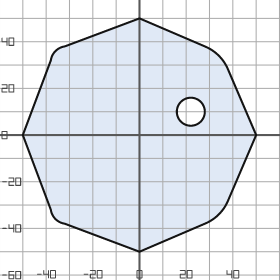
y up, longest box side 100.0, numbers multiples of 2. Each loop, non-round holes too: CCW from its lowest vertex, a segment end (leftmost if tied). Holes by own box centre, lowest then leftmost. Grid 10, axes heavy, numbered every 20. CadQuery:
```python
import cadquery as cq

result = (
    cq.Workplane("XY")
    .moveTo(0.0, -50.0)
    .lineTo(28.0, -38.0)
    .threePointArc((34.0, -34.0), (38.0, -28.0))
    .lineTo(50.0, 0.0)
    .lineTo(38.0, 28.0)
    .threePointArc((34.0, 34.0), (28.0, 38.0))
    .lineTo(0.0, 50.0)
    .lineTo(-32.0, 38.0)
    .threePointArc((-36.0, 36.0), (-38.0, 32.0))
    .lineTo(-50.0, 0.0)
    .lineTo(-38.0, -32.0)
    .threePointArc((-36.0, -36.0), (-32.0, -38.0))
    .close()
    .moveTo(22.0, 10.0)
    .circle(6.0)
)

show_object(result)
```